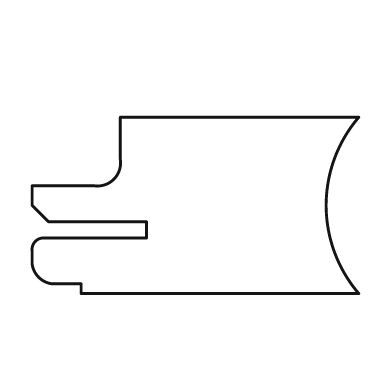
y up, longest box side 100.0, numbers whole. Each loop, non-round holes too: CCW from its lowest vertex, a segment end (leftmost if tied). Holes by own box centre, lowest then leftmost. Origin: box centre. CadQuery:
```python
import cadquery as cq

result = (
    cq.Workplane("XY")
    .moveTo(-35.0, -27.0)
    .lineTo(50.0, -27.0)
    .threePointArc((40.0, 0.0), (50.0, 27.0))
    .lineTo(-23.0, 27.0)
    .lineTo(-23.0, 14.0)
    .threePointArc((-25.0, 8.0), (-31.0, 6.0))
    .lineTo(-50.0, 6.0)
    .lineTo(-50.0, 0.0)
    .lineTo(-45.0, -5.0)
    .lineTo(-15.0, -5.0)
    .lineTo(-15.0, -10.0)
    .lineTo(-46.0, -10.0)
    .threePointArc((-49.0, -11.0), (-50.0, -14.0))
    .lineTo(-50.0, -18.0)
    .threePointArc((-48.0, -22.0), (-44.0, -24.0))
    .lineTo(-35.0, -24.0)
    .close()
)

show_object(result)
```